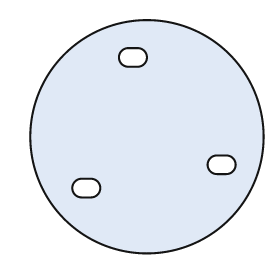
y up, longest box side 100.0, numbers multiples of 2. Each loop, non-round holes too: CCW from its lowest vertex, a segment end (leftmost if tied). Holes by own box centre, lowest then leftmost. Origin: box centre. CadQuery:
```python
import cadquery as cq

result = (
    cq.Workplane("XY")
    .moveTo(0.0, 0.0)
    .circle(50.0)
    .moveTo(-28.0, -26.0)
    .lineTo(-24.0, -26.0)
    .threePointArc((-20.0, -22.0), (-24.0, -18.0))
    .lineTo(-28.0, -18.0)
    .threePointArc((-32.0, -22.0), (-28.0, -26.0))
    .close()
    .moveTo(30.0, -16.0)
    .lineTo(34.0, -16.0)
    .threePointArc((38.0, -12.0), (34.0, -8.0))
    .lineTo(30.0, -8.0)
    .threePointArc((26.0, -12.0), (30.0, -16.0))
    .close()
    .moveTo(-8.0, 30.0)
    .lineTo(-4.0, 30.0)
    .threePointArc((0.0, 34.0), (-4.0, 38.0))
    .lineTo(-8.0, 38.0)
    .threePointArc((-12.0, 34.0), (-8.0, 30.0))
    .close()
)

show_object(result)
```